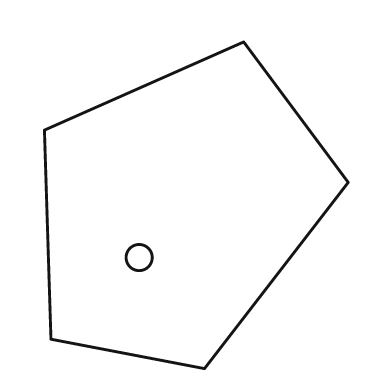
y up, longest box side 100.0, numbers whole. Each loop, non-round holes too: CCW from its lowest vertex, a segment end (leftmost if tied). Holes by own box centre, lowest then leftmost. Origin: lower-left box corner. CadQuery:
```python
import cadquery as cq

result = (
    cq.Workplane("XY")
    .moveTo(49.0, 0.0)
    .lineTo(93.0, 57.0)
    .lineTo(61.0, 100.0)
    .lineTo(0.0, 73.0)
    .lineTo(2.0, 9.0)
    .close()
    .moveTo(29.0, 34.0)
    .circle(4.0)
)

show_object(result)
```